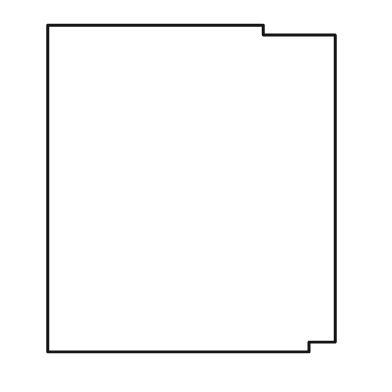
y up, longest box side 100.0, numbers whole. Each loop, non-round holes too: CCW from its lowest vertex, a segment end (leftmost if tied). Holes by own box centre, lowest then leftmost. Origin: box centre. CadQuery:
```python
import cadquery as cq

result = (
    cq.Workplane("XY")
    .moveTo(-44.0, -50.0)
    .lineTo(36.0, -50.0)
    .lineTo(36.0, -47.0)
    .lineTo(44.0, -47.0)
    .lineTo(44.0, 47.0)
    .lineTo(22.0, 47.0)
    .lineTo(22.0, 50.0)
    .lineTo(-44.0, 50.0)
    .close()
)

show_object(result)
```